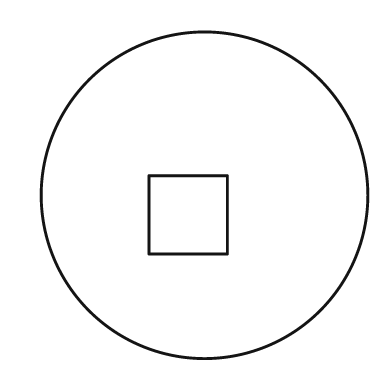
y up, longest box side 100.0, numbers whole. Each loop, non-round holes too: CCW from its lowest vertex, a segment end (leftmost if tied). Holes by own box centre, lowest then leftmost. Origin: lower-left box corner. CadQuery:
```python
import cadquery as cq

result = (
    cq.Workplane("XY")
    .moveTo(50.0, 50.0)
    .circle(50.0)
    .moveTo(33.0, 32.0)
    .lineTo(57.0, 32.0)
    .lineTo(57.0, 56.0)
    .lineTo(33.0, 56.0)
    .close()
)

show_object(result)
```